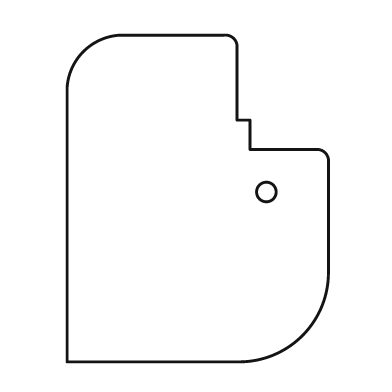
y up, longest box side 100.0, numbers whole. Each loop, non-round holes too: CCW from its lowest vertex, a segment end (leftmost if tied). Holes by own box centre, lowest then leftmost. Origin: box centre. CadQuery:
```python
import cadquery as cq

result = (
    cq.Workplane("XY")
    .moveTo(-40.0, -50.0)
    .lineTo(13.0, -50.0)
    .threePointArc((32.0, -42.0), (40.0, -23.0))
    .lineTo(40.0, 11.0)
    .threePointArc((39.0, 14.0), (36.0, 15.0))
    .lineTo(16.0, 15.0)
    .lineTo(16.0, 24.0)
    .lineTo(12.0, 24.0)
    .lineTo(12.0, 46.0)
    .threePointArc((11.0, 49.0), (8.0, 50.0))
    .lineTo(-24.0, 50.0)
    .threePointArc((-35.0, 45.0), (-40.0, 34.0))
    .close()
    .moveTo(21.0, 2.0)
    .circle(3.0)
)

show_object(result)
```